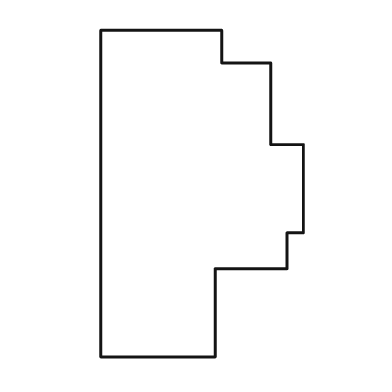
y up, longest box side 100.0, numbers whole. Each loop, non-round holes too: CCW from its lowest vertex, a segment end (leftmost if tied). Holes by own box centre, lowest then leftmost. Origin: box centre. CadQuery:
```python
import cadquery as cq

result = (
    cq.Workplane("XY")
    .moveTo(-31.0, -50.0)
    .lineTo(4.0, -50.0)
    .lineTo(4.0, -23.0)
    .lineTo(26.0, -23.0)
    .lineTo(26.0, -12.0)
    .lineTo(31.0, -12.0)
    .lineTo(31.0, 15.0)
    .lineTo(21.0, 15.0)
    .lineTo(21.0, 40.0)
    .lineTo(6.0, 40.0)
    .lineTo(6.0, 50.0)
    .lineTo(-31.0, 50.0)
    .close()
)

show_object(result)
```